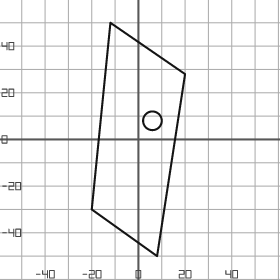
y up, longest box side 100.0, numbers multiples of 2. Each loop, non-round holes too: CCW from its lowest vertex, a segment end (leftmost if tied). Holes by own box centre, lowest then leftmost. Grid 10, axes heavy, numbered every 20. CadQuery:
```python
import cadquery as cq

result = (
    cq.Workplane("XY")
    .moveTo(8.0, -50.0)
    .lineTo(20.0, 28.0)
    .lineTo(-12.0, 50.0)
    .lineTo(-20.0, -30.0)
    .close()
    .moveTo(6.0, 8.0)
    .circle(4.0)
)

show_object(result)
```